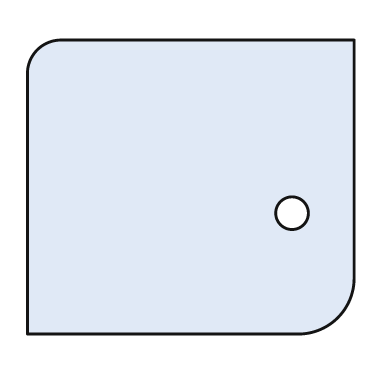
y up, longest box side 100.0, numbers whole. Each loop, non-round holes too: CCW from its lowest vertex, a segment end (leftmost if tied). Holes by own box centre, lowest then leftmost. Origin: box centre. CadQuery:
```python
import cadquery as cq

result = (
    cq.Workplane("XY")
    .moveTo(-50.0, -45.0)
    .lineTo(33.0, -45.0)
    .threePointArc((45.0, -40.0), (50.0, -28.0))
    .lineTo(50.0, 45.0)
    .lineTo(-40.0, 45.0)
    .threePointArc((-47.0, 42.0), (-50.0, 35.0))
    .close()
    .moveTo(31.0, -8.0)
    .circle(5.0)
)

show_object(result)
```